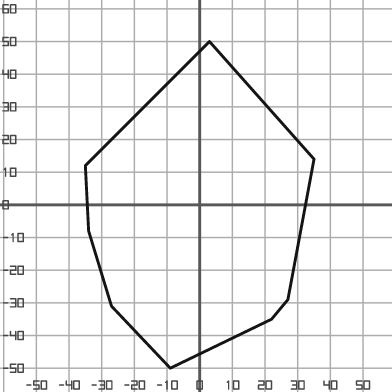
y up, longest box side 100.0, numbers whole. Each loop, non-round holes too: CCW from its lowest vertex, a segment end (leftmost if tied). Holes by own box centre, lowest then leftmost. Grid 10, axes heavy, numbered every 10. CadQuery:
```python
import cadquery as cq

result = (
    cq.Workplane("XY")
    .moveTo(-9.0, -50.0)
    .lineTo(22.0, -35.0)
    .lineTo(27.0, -29.0)
    .lineTo(35.0, 14.0)
    .lineTo(3.0, 50.0)
    .lineTo(-35.0, 12.0)
    .lineTo(-34.0, -8.0)
    .lineTo(-27.0, -31.0)
    .close()
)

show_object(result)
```